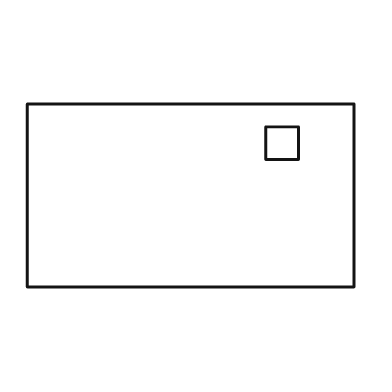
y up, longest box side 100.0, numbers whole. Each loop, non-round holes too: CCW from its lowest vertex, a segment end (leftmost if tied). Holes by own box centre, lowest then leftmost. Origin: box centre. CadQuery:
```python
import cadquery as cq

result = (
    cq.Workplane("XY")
    .moveTo(-50.0, -28.0)
    .lineTo(50.0, -28.0)
    .lineTo(50.0, 28.0)
    .lineTo(-50.0, 28.0)
    .close()
    .moveTo(23.0, 11.0)
    .lineTo(33.0, 11.0)
    .lineTo(33.0, 21.0)
    .lineTo(23.0, 21.0)
    .close()
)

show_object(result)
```